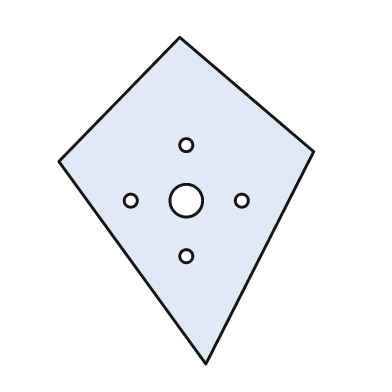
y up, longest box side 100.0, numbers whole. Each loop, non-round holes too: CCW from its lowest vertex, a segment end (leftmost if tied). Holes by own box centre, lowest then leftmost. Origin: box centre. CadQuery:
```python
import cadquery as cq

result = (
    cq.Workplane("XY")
    .moveTo(6.0, -50.0)
    .lineTo(39.0, 15.0)
    .lineTo(-2.0, 50.0)
    .lineTo(-39.0, 12.0)
    .close()
    .moveTo(0.0, -17.0)
    .circle(2.0)
    .moveTo(-17.0, 0.0)
    .circle(2.0)
    .moveTo(0.0, 0.0)
    .circle(5.0)
    .moveTo(17.0, 0.0)
    .circle(2.0)
    .moveTo(0.0, 17.0)
    .circle(2.0)
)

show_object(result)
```